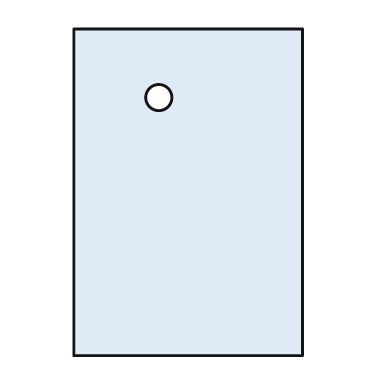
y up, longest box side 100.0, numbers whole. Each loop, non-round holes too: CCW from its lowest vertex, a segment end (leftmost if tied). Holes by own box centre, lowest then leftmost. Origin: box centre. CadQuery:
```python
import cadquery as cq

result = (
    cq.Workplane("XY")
    .moveTo(-35.0, -50.0)
    .lineTo(35.0, -50.0)
    .lineTo(35.0, 50.0)
    .lineTo(-35.0, 50.0)
    .close()
    .moveTo(-9.0, 29.0)
    .circle(4.0)
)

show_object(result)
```